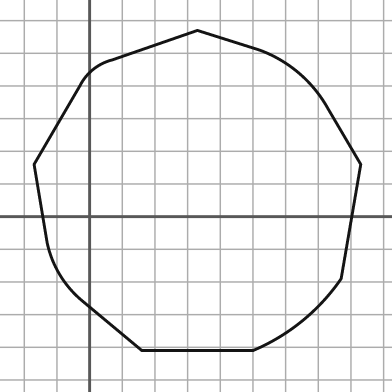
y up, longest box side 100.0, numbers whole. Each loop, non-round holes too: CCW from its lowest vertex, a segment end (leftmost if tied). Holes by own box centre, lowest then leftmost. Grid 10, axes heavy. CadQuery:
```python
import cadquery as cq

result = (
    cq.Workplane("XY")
    .moveTo(16.0, -41.0)
    .lineTo(50.0, -41.0)
    .threePointArc((65.0, -32.0), (77.0, -19.0))
    .lineTo(83.0, 16.0)
    .lineTo(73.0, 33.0)
    .threePointArc((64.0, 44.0), (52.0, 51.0))
    .lineTo(33.0, 57.0)
    .lineTo(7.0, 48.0)
    .threePointArc((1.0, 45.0), (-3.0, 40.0))
    .lineTo(-17.0, 16.0)
    .lineTo(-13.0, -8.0)
    .threePointArc((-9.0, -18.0), (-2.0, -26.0))
    .close()
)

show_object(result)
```